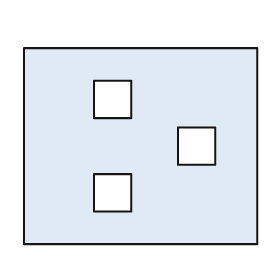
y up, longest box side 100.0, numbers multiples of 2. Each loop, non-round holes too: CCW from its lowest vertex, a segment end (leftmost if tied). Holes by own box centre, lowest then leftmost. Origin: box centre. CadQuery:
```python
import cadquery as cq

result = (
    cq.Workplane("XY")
    .moveTo(-50.0, -42.0)
    .lineTo(50.0, -42.0)
    .lineTo(50.0, 42.0)
    .lineTo(-50.0, 42.0)
    .close()
    .moveTo(-20.0, -28.0)
    .lineTo(-4.0, -28.0)
    .lineTo(-4.0, -12.0)
    .lineTo(-20.0, -12.0)
    .close()
    .moveTo(16.0, -8.0)
    .lineTo(32.0, -8.0)
    .lineTo(32.0, 8.0)
    .lineTo(16.0, 8.0)
    .close()
    .moveTo(-20.0, 12.0)
    .lineTo(-4.0, 12.0)
    .lineTo(-4.0, 28.0)
    .lineTo(-20.0, 28.0)
    .close()
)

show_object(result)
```